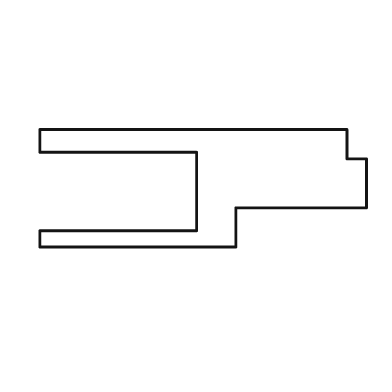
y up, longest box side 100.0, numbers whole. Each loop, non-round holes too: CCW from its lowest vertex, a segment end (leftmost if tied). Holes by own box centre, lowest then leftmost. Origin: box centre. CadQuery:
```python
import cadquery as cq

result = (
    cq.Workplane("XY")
    .moveTo(-50.0, -18.0)
    .lineTo(10.0, -18.0)
    .lineTo(10.0, -6.0)
    .lineTo(50.0, -6.0)
    .lineTo(50.0, 9.0)
    .lineTo(44.0, 9.0)
    .lineTo(44.0, 18.0)
    .lineTo(-50.0, 18.0)
    .lineTo(-50.0, 11.0)
    .lineTo(-2.0, 11.0)
    .lineTo(-2.0, -13.0)
    .lineTo(-50.0, -13.0)
    .close()
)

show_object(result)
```